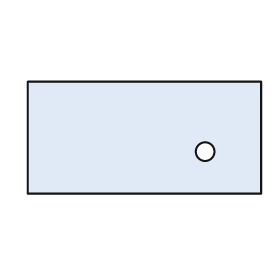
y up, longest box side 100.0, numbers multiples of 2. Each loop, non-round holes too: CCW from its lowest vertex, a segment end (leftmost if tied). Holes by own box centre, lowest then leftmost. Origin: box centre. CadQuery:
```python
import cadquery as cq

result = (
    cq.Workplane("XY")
    .moveTo(-50.0, -24.0)
    .lineTo(50.0, -24.0)
    .lineTo(50.0, 24.0)
    .lineTo(-50.0, 24.0)
    .close()
    .moveTo(26.0, -6.0)
    .circle(4.0)
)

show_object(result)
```